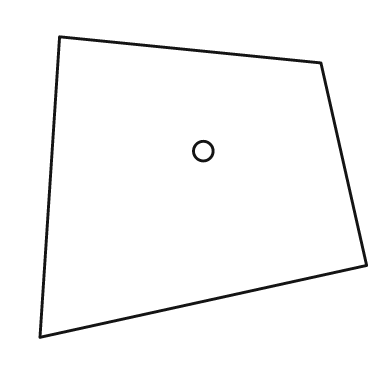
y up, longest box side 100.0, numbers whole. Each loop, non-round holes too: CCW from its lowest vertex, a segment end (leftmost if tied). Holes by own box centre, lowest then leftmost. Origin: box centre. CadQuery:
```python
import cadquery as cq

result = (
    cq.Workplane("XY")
    .moveTo(-50.0, -46.0)
    .lineTo(50.0, -24.0)
    .lineTo(36.0, 38.0)
    .lineTo(-44.0, 46.0)
    .close()
    .moveTo(0.0, 11.0)
    .circle(3.0)
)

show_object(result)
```